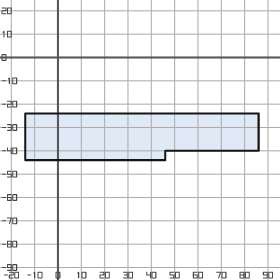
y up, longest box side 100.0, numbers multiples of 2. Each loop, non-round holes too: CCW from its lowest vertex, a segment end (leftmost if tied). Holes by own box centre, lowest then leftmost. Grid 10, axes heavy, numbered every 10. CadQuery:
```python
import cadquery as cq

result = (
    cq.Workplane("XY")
    .moveTo(-14.0, -44.0)
    .lineTo(46.0, -44.0)
    .lineTo(46.0, -40.0)
    .lineTo(86.0, -40.0)
    .lineTo(86.0, -24.0)
    .lineTo(-14.0, -24.0)
    .close()
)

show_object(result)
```